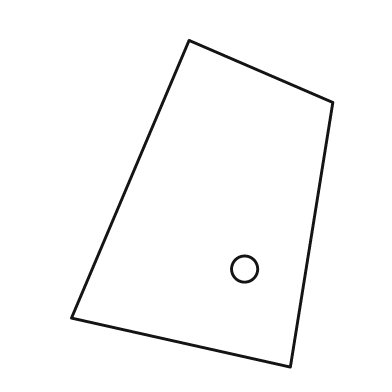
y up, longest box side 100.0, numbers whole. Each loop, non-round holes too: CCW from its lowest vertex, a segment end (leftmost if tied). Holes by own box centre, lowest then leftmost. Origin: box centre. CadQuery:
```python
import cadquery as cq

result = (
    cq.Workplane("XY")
    .moveTo(27.0, -50.0)
    .lineTo(40.0, 31.0)
    .lineTo(-4.0, 50.0)
    .lineTo(-40.0, -35.0)
    .close()
    .moveTo(13.0, -20.0)
    .circle(4.0)
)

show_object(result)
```